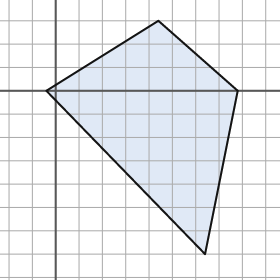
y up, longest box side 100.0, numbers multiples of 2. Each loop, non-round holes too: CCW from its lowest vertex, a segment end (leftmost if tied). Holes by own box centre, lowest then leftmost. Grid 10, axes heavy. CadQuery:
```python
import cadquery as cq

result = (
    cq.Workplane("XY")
    .moveTo(64.0, -70.0)
    .lineTo(78.0, 0.0)
    .lineTo(44.0, 30.0)
    .lineTo(-4.0, 0.0)
    .close()
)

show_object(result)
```